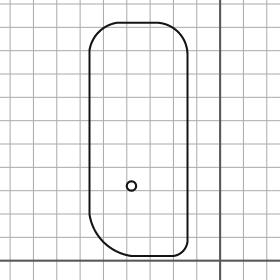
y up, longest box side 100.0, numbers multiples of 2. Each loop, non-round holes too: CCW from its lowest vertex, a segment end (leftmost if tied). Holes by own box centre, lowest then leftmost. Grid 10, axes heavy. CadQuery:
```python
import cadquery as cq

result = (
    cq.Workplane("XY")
    .moveTo(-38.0, 2.0)
    .lineTo(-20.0, 2.0)
    .threePointArc((-16.0, 4.0), (-14.0, 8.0))
    .lineTo(-14.0, 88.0)
    .threePointArc((-18.0, 98.0), (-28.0, 102.0))
    .lineTo(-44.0, 102.0)
    .threePointArc((-52.0, 98.0), (-56.0, 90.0))
    .lineTo(-56.0, 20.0)
    .threePointArc((-50.0, 8.0), (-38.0, 2.0))
    .close()
    .moveTo(-38.0, 32.0)
    .circle(2.0)
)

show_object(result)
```